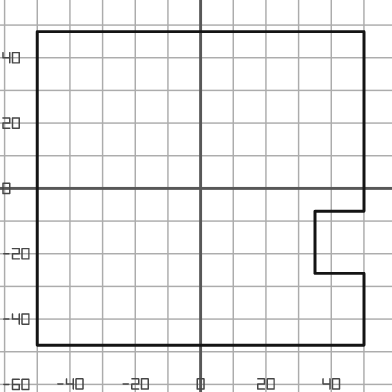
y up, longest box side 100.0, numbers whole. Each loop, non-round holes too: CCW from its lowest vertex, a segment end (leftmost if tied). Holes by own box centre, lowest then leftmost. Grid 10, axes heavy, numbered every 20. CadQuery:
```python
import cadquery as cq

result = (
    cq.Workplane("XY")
    .moveTo(-50.0, -48.0)
    .lineTo(50.0, -48.0)
    .lineTo(50.0, -26.0)
    .lineTo(35.0, -26.0)
    .lineTo(35.0, -7.0)
    .lineTo(50.0, -7.0)
    .lineTo(50.0, 48.0)
    .lineTo(-50.0, 48.0)
    .close()
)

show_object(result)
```